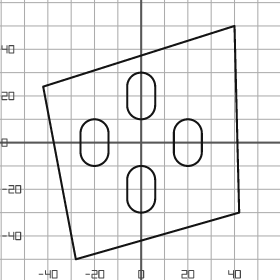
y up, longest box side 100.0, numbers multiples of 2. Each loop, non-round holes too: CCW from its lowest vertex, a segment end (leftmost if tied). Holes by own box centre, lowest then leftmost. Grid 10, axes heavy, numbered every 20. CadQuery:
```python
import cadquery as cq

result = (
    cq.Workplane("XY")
    .moveTo(-28.0, -50.0)
    .lineTo(42.0, -30.0)
    .lineTo(40.0, 50.0)
    .lineTo(-42.0, 24.0)
    .close()
    .moveTo(-6.0, -24.0)
    .threePointArc((0.0, -30.0), (6.0, -24.0))
    .lineTo(6.0, -16.0)
    .threePointArc((0.0, -10.0), (-6.0, -16.0))
    .close()
    .moveTo(-26.0, -4.0)
    .threePointArc((-20.0, -10.0), (-14.0, -4.0))
    .lineTo(-14.0, 4.0)
    .threePointArc((-20.0, 10.0), (-26.0, 4.0))
    .close()
    .moveTo(14.0, -4.0)
    .threePointArc((20.0, -10.0), (26.0, -4.0))
    .lineTo(26.0, 4.0)
    .threePointArc((20.0, 10.0), (14.0, 4.0))
    .close()
    .moveTo(-6.0, 16.0)
    .threePointArc((0.0, 10.0), (6.0, 16.0))
    .lineTo(6.0, 24.0)
    .threePointArc((0.0, 30.0), (-6.0, 24.0))
    .close()
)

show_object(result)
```